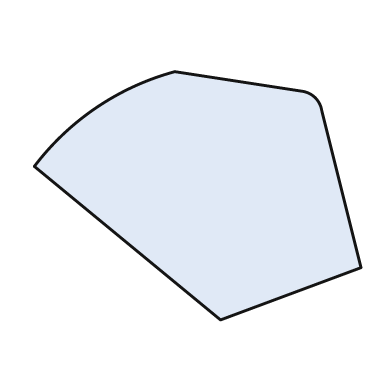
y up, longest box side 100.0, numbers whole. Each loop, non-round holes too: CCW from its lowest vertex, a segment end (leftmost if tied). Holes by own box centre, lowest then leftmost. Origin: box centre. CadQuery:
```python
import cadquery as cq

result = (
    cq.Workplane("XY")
    .moveTo(7.0, -38.0)
    .lineTo(50.0, -22.0)
    .lineTo(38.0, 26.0)
    .threePointArc((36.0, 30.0), (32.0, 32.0))
    .lineTo(-7.0, 38.0)
    .threePointArc((-31.0, 27.0), (-50.0, 9.0))
    .close()
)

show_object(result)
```